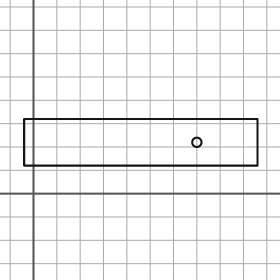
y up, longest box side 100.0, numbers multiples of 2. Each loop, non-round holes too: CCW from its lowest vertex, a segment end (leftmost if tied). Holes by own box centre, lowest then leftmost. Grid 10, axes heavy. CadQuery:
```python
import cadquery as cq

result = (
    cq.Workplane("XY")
    .moveTo(-4.0, 12.0)
    .lineTo(96.0, 12.0)
    .lineTo(96.0, 32.0)
    .lineTo(-4.0, 32.0)
    .close()
    .moveTo(70.0, 22.0)
    .circle(2.0)
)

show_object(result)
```